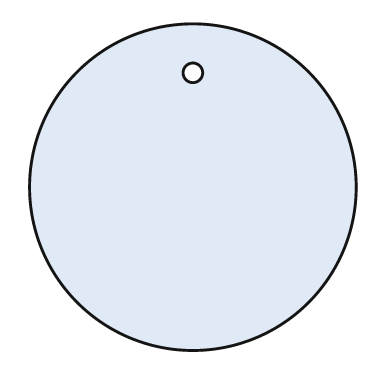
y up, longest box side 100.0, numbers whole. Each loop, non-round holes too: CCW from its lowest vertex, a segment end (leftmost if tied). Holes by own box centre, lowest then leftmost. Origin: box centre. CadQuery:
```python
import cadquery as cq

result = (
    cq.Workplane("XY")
    .moveTo(0.0, 0.0)
    .circle(50.0)
    .moveTo(0.0, 35.0)
    .circle(3.0)
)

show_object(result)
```